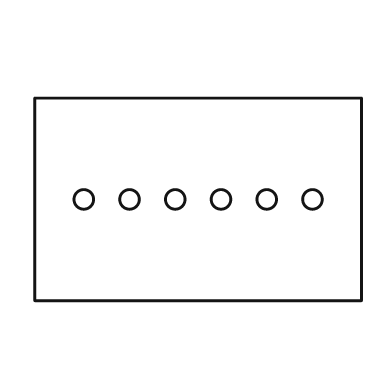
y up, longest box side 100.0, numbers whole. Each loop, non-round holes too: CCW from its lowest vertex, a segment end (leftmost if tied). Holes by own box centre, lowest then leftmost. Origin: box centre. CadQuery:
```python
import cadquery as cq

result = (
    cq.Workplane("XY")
    .moveTo(-50.0, -31.0)
    .lineTo(50.0, -31.0)
    .lineTo(50.0, 31.0)
    .lineTo(-50.0, 31.0)
    .close()
    .moveTo(-35.0, 0.0)
    .circle(3.0)
    .moveTo(-21.0, 0.0)
    .circle(3.0)
    .moveTo(-7.0, 0.0)
    .circle(3.0)
    .moveTo(7.0, 0.0)
    .circle(3.0)
    .moveTo(21.0, 0.0)
    .circle(3.0)
    .moveTo(35.0, 0.0)
    .circle(3.0)
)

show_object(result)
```